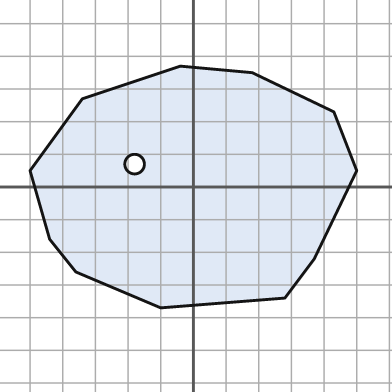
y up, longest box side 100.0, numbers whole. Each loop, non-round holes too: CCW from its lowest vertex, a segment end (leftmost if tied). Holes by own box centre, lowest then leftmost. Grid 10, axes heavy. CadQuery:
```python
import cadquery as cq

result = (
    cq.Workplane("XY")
    .moveTo(-10.0, -37.0)
    .lineTo(28.0, -34.0)
    .lineTo(37.0, -22.0)
    .lineTo(50.0, 5.0)
    .lineTo(43.0, 23.0)
    .lineTo(18.0, 35.0)
    .lineTo(-4.0, 37.0)
    .lineTo(-34.0, 27.0)
    .lineTo(-50.0, 5.0)
    .lineTo(-44.0, -16.0)
    .lineTo(-36.0, -26.0)
    .close()
    .moveTo(-18.0, 7.0)
    .circle(3.0)
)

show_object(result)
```